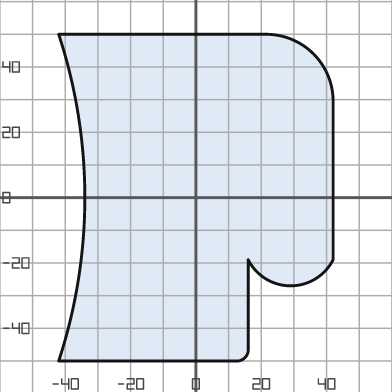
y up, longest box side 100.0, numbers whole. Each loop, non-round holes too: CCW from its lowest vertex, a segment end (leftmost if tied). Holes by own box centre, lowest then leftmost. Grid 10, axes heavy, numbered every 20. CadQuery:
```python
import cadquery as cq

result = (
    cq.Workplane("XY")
    .moveTo(-42.0, -50.0)
    .lineTo(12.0, -50.0)
    .threePointArc((15.0, -49.0), (16.0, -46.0))
    .lineTo(16.0, -19.0)
    .threePointArc((29.0, -27.0), (42.0, -19.0))
    .lineTo(42.0, 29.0)
    .threePointArc((36.0, 44.0), (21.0, 50.0))
    .lineTo(-42.0, 50.0)
    .threePointArc((-34.0, 0.0), (-42.0, -50.0))
    .close()
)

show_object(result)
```